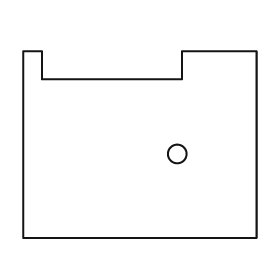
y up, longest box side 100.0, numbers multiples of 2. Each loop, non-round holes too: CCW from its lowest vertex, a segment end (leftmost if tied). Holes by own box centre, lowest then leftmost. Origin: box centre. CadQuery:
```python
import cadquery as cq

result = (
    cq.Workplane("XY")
    .moveTo(-50.0, -40.0)
    .lineTo(50.0, -40.0)
    .lineTo(50.0, 40.0)
    .lineTo(18.0, 40.0)
    .lineTo(18.0, 28.0)
    .lineTo(-42.0, 28.0)
    .lineTo(-42.0, 40.0)
    .lineTo(-50.0, 40.0)
    .close()
    .moveTo(16.0, -4.0)
    .circle(4.0)
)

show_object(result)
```